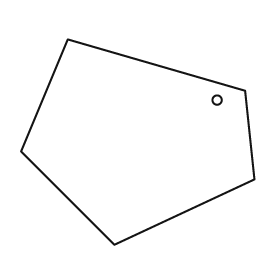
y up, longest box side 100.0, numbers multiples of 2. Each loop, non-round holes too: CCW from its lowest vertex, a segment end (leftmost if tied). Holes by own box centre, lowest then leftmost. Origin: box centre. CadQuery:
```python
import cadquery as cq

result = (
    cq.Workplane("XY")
    .moveTo(-10.0, -44.0)
    .lineTo(50.0, -16.0)
    .lineTo(46.0, 22.0)
    .lineTo(-30.0, 44.0)
    .lineTo(-50.0, -4.0)
    .close()
    .moveTo(34.0, 18.0)
    .circle(2.0)
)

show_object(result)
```